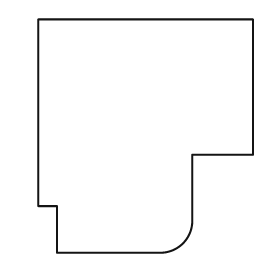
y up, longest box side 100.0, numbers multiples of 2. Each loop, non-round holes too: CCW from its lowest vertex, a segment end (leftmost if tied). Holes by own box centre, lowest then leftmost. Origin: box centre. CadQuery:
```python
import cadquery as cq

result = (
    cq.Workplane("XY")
    .moveTo(-38.0, -50.0)
    .lineTo(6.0, -50.0)
    .threePointArc((16.0, -46.0), (20.0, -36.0))
    .lineTo(20.0, -8.0)
    .lineTo(46.0, -8.0)
    .lineTo(46.0, 50.0)
    .lineTo(-46.0, 50.0)
    .lineTo(-46.0, -30.0)
    .lineTo(-38.0, -30.0)
    .close()
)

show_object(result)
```